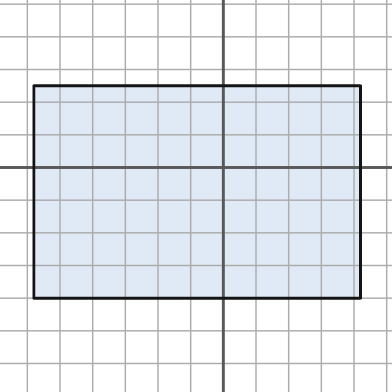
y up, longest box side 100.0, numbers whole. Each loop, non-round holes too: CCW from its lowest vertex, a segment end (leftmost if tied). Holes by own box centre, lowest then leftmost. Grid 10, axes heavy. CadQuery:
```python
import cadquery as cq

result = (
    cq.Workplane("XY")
    .moveTo(-58.0, -40.0)
    .lineTo(42.0, -40.0)
    .lineTo(42.0, 25.0)
    .lineTo(-58.0, 25.0)
    .close()
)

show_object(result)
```